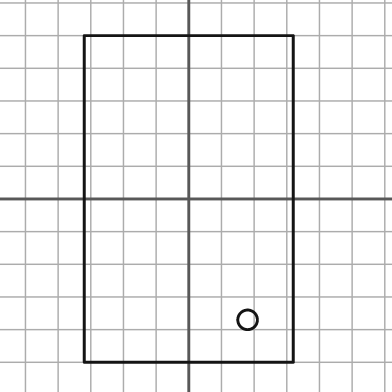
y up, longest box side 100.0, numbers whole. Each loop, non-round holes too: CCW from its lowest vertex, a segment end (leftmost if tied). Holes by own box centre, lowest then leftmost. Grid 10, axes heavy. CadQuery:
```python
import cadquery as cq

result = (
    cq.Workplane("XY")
    .moveTo(-32.0, -50.0)
    .lineTo(32.0, -50.0)
    .lineTo(32.0, 50.0)
    .lineTo(-32.0, 50.0)
    .close()
    .moveTo(18.0, -37.0)
    .circle(3.0)
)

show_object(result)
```